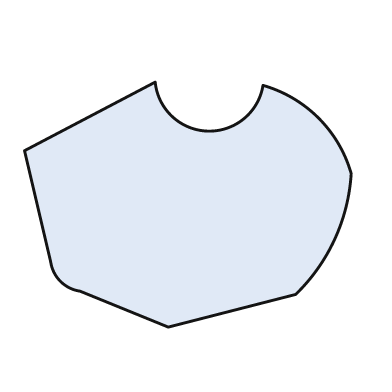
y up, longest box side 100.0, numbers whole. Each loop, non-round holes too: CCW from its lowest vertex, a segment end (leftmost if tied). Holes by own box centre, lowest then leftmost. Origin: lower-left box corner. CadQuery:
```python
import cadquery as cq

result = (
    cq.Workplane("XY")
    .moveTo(44.0, 0.0)
    .lineTo(83.0, 10.0)
    .threePointArc((95.0, 27.0), (100.0, 47.0))
    .threePointArc((90.0, 64.0), (73.0, 74.0))
    .threePointArc((56.0, 60.0), (40.0, 75.0))
    .lineTo(0.0, 54.0)
    .lineTo(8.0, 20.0)
    .threePointArc((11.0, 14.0), (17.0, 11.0))
    .close()
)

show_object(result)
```